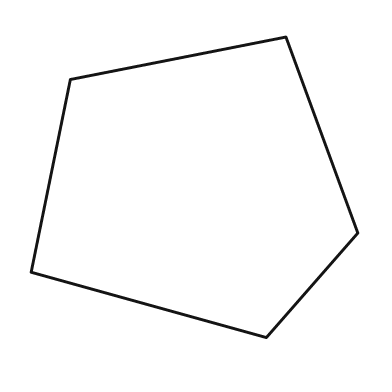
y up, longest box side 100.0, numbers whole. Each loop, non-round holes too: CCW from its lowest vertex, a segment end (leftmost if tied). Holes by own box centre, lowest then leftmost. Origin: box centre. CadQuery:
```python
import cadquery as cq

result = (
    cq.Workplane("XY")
    .moveTo(22.0, -46.0)
    .lineTo(50.0, -14.0)
    .lineTo(28.0, 46.0)
    .lineTo(-38.0, 33.0)
    .lineTo(-50.0, -26.0)
    .close()
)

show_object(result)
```